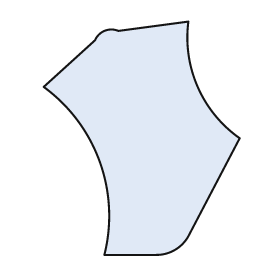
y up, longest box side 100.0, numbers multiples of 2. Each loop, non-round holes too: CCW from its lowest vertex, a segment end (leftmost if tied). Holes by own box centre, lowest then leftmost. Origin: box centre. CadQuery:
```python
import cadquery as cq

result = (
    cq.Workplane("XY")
    .moveTo(-16.0, -50.0)
    .lineTo(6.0, -50.0)
    .threePointArc((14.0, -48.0), (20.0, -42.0))
    .lineTo(42.0, 0.0)
    .threePointArc((24.0, 22.0), (20.0, 50.0))
    .lineTo(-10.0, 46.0)
    .threePointArc((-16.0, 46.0), (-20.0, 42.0))
    .lineTo(-42.0, 22.0)
    .threePointArc((-18.0, -10.0), (-16.0, -50.0))
    .close()
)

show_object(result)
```